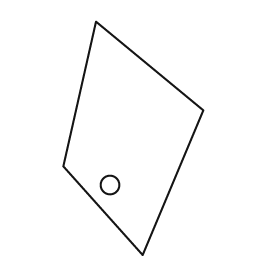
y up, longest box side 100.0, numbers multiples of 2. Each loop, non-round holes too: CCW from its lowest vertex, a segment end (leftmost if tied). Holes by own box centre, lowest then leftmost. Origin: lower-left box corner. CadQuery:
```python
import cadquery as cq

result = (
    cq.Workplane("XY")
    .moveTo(34.0, 0.0)
    .lineTo(60.0, 62.0)
    .lineTo(14.0, 100.0)
    .lineTo(0.0, 38.0)
    .close()
    .moveTo(20.0, 30.0)
    .circle(4.0)
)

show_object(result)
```